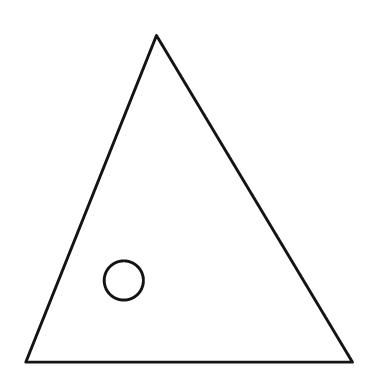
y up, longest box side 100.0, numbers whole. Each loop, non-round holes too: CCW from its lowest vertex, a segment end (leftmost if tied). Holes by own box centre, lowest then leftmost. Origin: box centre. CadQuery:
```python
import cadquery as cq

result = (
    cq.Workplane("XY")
    .moveTo(-50.0, -50.0)
    .lineTo(50.0, -50.0)
    .lineTo(-10.0, 50.0)
    .close()
    .moveTo(-20.0, -25.0)
    .circle(6.0)
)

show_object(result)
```